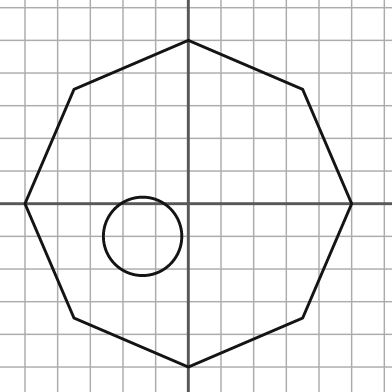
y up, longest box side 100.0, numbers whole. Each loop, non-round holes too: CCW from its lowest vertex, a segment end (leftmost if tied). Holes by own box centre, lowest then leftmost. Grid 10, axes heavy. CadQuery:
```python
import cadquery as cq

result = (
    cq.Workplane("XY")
    .moveTo(0.0, -50.0)
    .lineTo(35.0, -35.0)
    .lineTo(50.0, 0.0)
    .lineTo(35.0, 35.0)
    .lineTo(0.0, 50.0)
    .lineTo(-35.0, 35.0)
    .lineTo(-50.0, 0.0)
    .lineTo(-35.0, -35.0)
    .close()
    .moveTo(-14.0, -10.0)
    .circle(12.0)
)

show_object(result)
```